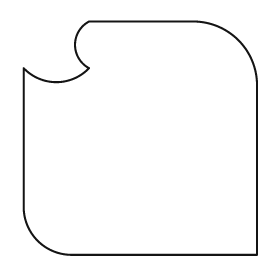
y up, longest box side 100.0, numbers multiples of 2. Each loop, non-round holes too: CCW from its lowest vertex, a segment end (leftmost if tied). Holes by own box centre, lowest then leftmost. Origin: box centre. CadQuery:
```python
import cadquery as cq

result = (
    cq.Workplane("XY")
    .moveTo(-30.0, -50.0)
    .lineTo(50.0, -50.0)
    .lineTo(50.0, 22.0)
    .threePointArc((42.0, 42.0), (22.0, 50.0))
    .lineTo(-22.0, 50.0)
    .threePointArc((-28.0, 40.0), (-22.0, 30.0))
    .threePointArc((-36.0, 24.0), (-50.0, 30.0))
    .lineTo(-50.0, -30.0)
    .threePointArc((-44.0, -44.0), (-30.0, -50.0))
    .close()
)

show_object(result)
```